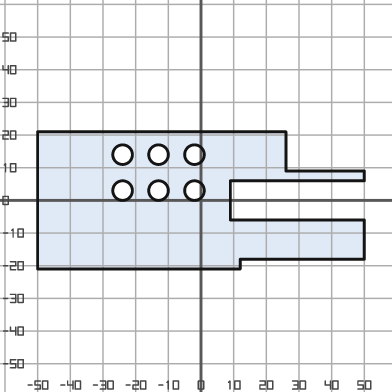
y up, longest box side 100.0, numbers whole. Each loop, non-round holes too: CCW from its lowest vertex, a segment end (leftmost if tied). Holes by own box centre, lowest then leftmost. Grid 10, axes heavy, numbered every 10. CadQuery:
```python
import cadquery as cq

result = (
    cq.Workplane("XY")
    .moveTo(-50.0, -21.0)
    .lineTo(12.0, -21.0)
    .lineTo(12.0, -18.0)
    .lineTo(50.0, -18.0)
    .lineTo(50.0, -6.0)
    .lineTo(9.0, -6.0)
    .lineTo(9.0, 6.0)
    .lineTo(50.0, 6.0)
    .lineTo(50.0, 9.0)
    .lineTo(26.0, 9.0)
    .lineTo(26.0, 21.0)
    .lineTo(-50.0, 21.0)
    .close()
    .moveTo(-24.0, 3.0)
    .circle(3.0)
    .moveTo(-13.0, 3.0)
    .circle(3.0)
    .moveTo(-2.0, 3.0)
    .circle(3.0)
    .moveTo(-24.0, 14.0)
    .circle(3.0)
    .moveTo(-13.0, 14.0)
    .circle(3.0)
    .moveTo(-2.0, 14.0)
    .circle(3.0)
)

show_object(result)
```